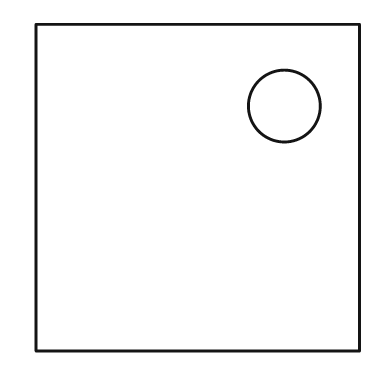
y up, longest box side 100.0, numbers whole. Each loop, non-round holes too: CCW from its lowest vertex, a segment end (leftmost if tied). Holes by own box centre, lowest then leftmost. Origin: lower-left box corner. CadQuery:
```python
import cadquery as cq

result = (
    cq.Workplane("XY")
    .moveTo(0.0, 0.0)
    .lineTo(99.0, 0.0)
    .lineTo(99.0, 100.0)
    .lineTo(0.0, 100.0)
    .close()
    .moveTo(76.0, 75.0)
    .circle(11.0)
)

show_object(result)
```